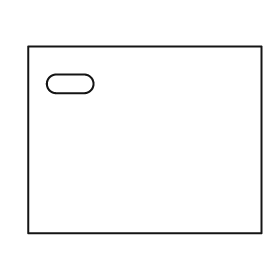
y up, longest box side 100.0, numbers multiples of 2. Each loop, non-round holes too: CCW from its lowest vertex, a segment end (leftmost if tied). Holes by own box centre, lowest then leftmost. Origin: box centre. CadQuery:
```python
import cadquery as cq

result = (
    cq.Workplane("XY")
    .moveTo(-50.0, -40.0)
    .lineTo(50.0, -40.0)
    .lineTo(50.0, 40.0)
    .lineTo(-50.0, 40.0)
    .close()
    .moveTo(-38.0, 20.0)
    .lineTo(-26.0, 20.0)
    .threePointArc((-22.0, 24.0), (-26.0, 28.0))
    .lineTo(-38.0, 28.0)
    .threePointArc((-42.0, 24.0), (-38.0, 20.0))
    .close()
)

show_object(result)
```